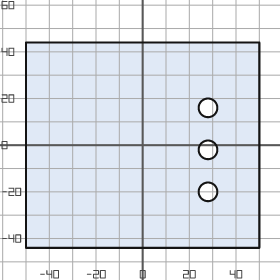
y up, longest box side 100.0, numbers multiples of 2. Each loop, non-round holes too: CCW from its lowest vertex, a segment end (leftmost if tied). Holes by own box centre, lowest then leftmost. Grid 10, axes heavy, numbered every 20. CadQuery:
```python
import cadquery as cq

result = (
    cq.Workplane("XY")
    .moveTo(-50.0, -44.0)
    .lineTo(50.0, -44.0)
    .lineTo(50.0, 44.0)
    .lineTo(-50.0, 44.0)
    .close()
    .moveTo(28.0, -20.0)
    .circle(4.0)
    .moveTo(28.0, -2.0)
    .circle(4.0)
    .moveTo(28.0, 16.0)
    .circle(4.0)
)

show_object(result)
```